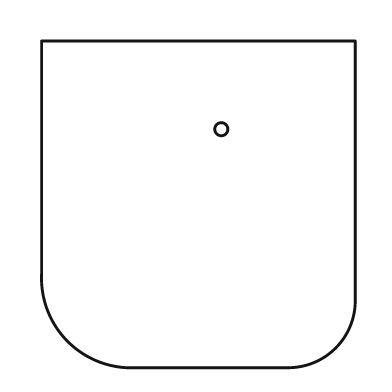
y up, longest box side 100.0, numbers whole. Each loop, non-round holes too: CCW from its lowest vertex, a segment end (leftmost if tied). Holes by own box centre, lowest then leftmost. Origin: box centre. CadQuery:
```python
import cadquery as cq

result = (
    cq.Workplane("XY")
    .moveTo(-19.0, -50.0)
    .lineTo(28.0, -50.0)
    .threePointArc((42.0, -44.0), (48.0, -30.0))
    .lineTo(48.0, 50.0)
    .lineTo(-48.0, 50.0)
    .lineTo(-48.0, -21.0)
    .threePointArc((-40.0, -42.0), (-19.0, -50.0))
    .close()
    .moveTo(7.0, 23.0)
    .circle(2.0)
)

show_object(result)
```